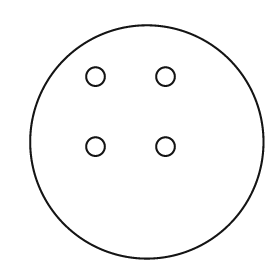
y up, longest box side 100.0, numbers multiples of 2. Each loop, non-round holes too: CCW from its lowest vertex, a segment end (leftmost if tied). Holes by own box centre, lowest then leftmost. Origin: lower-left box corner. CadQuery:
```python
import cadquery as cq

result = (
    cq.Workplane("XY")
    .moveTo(50.0, 50.0)
    .circle(50.0)
    .moveTo(28.0, 48.0)
    .circle(4.0)
    .moveTo(58.0, 48.0)
    .circle(4.0)
    .moveTo(28.0, 78.0)
    .circle(4.0)
    .moveTo(58.0, 78.0)
    .circle(4.0)
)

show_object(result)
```